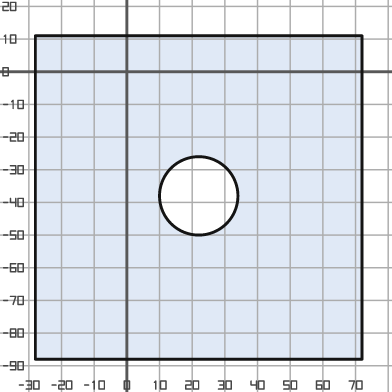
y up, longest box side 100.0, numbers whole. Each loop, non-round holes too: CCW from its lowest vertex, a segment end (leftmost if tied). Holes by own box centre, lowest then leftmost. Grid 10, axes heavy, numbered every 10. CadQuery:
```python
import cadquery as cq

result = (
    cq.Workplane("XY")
    .moveTo(-28.0, -88.0)
    .lineTo(72.0, -88.0)
    .lineTo(72.0, 11.0)
    .lineTo(-28.0, 11.0)
    .close()
    .moveTo(22.0, -38.0)
    .circle(12.0)
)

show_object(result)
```